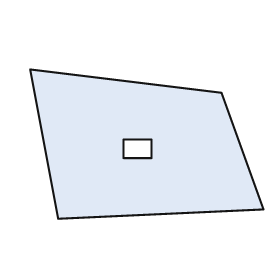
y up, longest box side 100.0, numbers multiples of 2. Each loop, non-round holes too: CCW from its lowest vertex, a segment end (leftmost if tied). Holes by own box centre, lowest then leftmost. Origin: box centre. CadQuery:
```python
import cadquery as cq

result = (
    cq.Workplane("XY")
    .moveTo(-38.0, -32.0)
    .lineTo(50.0, -28.0)
    .lineTo(32.0, 22.0)
    .lineTo(-50.0, 32.0)
    .close()
    .moveTo(-10.0, -6.0)
    .lineTo(2.0, -6.0)
    .lineTo(2.0, 2.0)
    .lineTo(-10.0, 2.0)
    .close()
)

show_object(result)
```